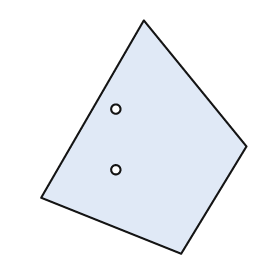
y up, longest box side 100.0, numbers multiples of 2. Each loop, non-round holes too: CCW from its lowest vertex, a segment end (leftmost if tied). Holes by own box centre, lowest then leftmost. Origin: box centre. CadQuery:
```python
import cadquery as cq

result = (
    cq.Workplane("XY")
    .moveTo(16.0, -50.0)
    .lineTo(44.0, -4.0)
    .lineTo(0.0, 50.0)
    .lineTo(-44.0, -26.0)
    .close()
    .moveTo(-12.0, -14.0)
    .circle(2.0)
    .moveTo(-12.0, 12.0)
    .circle(2.0)
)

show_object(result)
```